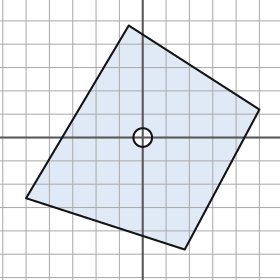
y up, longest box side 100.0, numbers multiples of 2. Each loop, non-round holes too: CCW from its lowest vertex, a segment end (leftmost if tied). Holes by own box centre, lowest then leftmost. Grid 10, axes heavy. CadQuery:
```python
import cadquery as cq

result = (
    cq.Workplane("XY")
    .moveTo(18.0, -48.0)
    .lineTo(50.0, 12.0)
    .lineTo(-6.0, 48.0)
    .lineTo(-50.0, -26.0)
    .close()
    .moveTo(0.0, 0.0)
    .circle(4.0)
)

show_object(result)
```